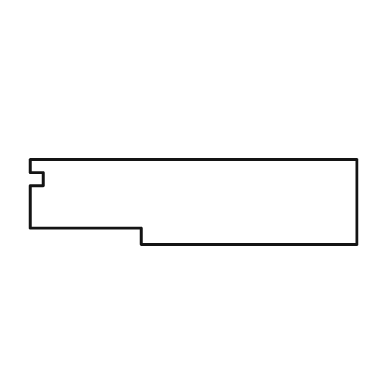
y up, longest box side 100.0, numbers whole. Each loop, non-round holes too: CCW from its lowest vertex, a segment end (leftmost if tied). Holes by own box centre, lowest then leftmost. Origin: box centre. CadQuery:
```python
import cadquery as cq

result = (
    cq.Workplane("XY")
    .moveTo(-16.0, -13.0)
    .lineTo(50.0, -13.0)
    .lineTo(50.0, 13.0)
    .lineTo(-50.0, 13.0)
    .lineTo(-50.0, 9.0)
    .lineTo(-46.0, 9.0)
    .lineTo(-46.0, 5.0)
    .lineTo(-50.0, 5.0)
    .lineTo(-50.0, -8.0)
    .lineTo(-16.0, -8.0)
    .close()
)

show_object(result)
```